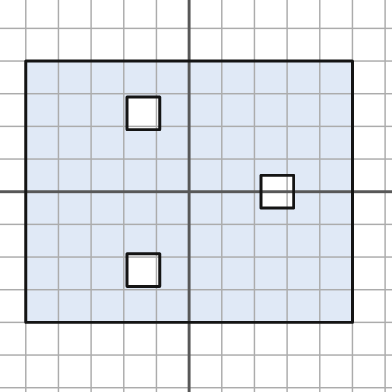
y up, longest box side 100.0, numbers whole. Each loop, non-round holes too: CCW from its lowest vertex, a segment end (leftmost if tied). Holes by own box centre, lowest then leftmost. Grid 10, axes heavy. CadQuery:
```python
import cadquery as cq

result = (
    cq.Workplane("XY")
    .moveTo(-50.0, -40.0)
    .lineTo(50.0, -40.0)
    .lineTo(50.0, 40.0)
    .lineTo(-50.0, 40.0)
    .close()
    .moveTo(-19.0, -29.0)
    .lineTo(-9.0, -29.0)
    .lineTo(-9.0, -19.0)
    .lineTo(-19.0, -19.0)
    .close()
    .moveTo(22.0, -5.0)
    .lineTo(32.0, -5.0)
    .lineTo(32.0, 5.0)
    .lineTo(22.0, 5.0)
    .close()
    .moveTo(-19.0, 19.0)
    .lineTo(-9.0, 19.0)
    .lineTo(-9.0, 29.0)
    .lineTo(-19.0, 29.0)
    .close()
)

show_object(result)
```